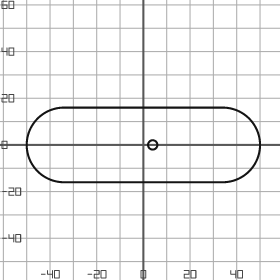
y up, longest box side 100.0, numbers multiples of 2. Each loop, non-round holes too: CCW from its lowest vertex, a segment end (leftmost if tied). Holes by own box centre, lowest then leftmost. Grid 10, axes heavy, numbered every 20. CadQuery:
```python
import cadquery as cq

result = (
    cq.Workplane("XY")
    .moveTo(-34.0, -16.0)
    .lineTo(34.0, -16.0)
    .threePointArc((50.0, 0.0), (34.0, 16.0))
    .lineTo(-34.0, 16.0)
    .threePointArc((-50.0, 0.0), (-34.0, -16.0))
    .close()
    .moveTo(4.0, 0.0)
    .circle(2.0)
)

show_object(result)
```